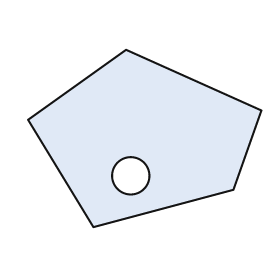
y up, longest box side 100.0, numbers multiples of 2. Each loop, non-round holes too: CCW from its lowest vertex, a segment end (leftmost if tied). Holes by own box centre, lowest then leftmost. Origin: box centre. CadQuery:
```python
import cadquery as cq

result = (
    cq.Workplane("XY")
    .moveTo(-22.0, -38.0)
    .lineTo(38.0, -22.0)
    .lineTo(50.0, 12.0)
    .lineTo(-8.0, 38.0)
    .lineTo(-50.0, 8.0)
    .close()
    .moveTo(-6.0, -16.0)
    .circle(8.0)
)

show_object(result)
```